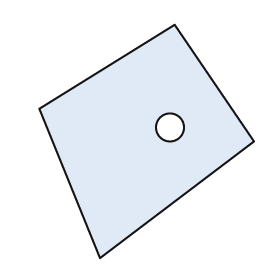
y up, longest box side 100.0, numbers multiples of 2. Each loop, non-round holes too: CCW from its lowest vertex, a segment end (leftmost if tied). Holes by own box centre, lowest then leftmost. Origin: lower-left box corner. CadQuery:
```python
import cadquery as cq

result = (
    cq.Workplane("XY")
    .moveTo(26.0, 0.0)
    .lineTo(92.0, 50.0)
    .lineTo(58.0, 100.0)
    .lineTo(0.0, 64.0)
    .close()
    .moveTo(56.0, 56.0)
    .circle(6.0)
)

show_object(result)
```